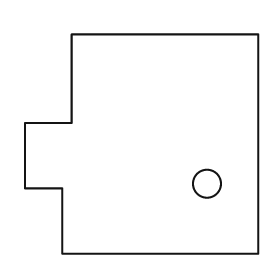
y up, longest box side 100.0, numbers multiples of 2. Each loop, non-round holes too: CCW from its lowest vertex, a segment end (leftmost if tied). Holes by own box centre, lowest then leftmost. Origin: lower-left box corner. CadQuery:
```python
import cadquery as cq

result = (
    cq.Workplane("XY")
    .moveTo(16.0, 0.0)
    .lineTo(100.0, 0.0)
    .lineTo(100.0, 94.0)
    .lineTo(20.0, 94.0)
    .lineTo(20.0, 56.0)
    .lineTo(0.0, 56.0)
    .lineTo(0.0, 28.0)
    .lineTo(16.0, 28.0)
    .close()
    .moveTo(78.0, 30.0)
    .circle(6.0)
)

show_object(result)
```